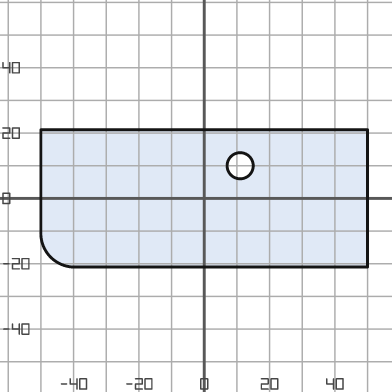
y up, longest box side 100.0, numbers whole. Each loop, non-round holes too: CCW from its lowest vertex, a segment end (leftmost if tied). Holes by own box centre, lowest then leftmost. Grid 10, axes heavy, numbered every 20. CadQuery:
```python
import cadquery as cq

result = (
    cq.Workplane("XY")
    .moveTo(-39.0, -21.0)
    .lineTo(50.0, -21.0)
    .lineTo(50.0, 21.0)
    .lineTo(-50.0, 21.0)
    .lineTo(-50.0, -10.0)
    .threePointArc((-47.0, -18.0), (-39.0, -21.0))
    .close()
    .moveTo(11.0, 10.0)
    .circle(4.0)
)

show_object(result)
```